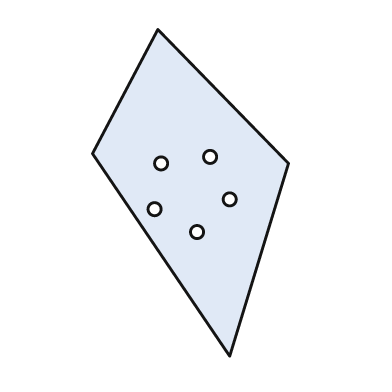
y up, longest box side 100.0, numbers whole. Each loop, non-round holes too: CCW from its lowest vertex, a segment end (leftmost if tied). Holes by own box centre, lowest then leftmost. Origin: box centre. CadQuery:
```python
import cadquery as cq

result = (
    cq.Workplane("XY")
    .moveTo(12.0, -50.0)
    .lineTo(30.0, 9.0)
    .lineTo(-10.0, 50.0)
    .lineTo(-30.0, 12.0)
    .close()
    .moveTo(2.0, -12.0)
    .circle(2.0)
    .moveTo(-11.0, -5.0)
    .circle(2.0)
    .moveTo(12.0, -2.0)
    .circle(2.0)
    .moveTo(-9.0, 9.0)
    .circle(2.0)
    .moveTo(6.0, 11.0)
    .circle(2.0)
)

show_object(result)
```